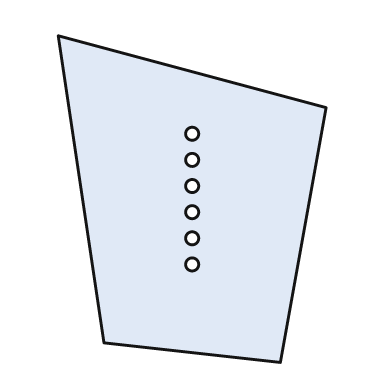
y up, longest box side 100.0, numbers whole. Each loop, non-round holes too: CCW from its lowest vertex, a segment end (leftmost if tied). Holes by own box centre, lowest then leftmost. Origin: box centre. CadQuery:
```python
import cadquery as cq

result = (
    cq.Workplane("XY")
    .moveTo(27.0, -50.0)
    .lineTo(41.0, 28.0)
    .lineTo(-41.0, 50.0)
    .lineTo(-27.0, -44.0)
    .close()
    .moveTo(0.0, -20.0)
    .circle(2.0)
    .moveTo(0.0, -12.0)
    .circle(2.0)
    .moveTo(0.0, -4.0)
    .circle(2.0)
    .moveTo(0.0, 4.0)
    .circle(2.0)
    .moveTo(0.0, 12.0)
    .circle(2.0)
    .moveTo(0.0, 20.0)
    .circle(2.0)
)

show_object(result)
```